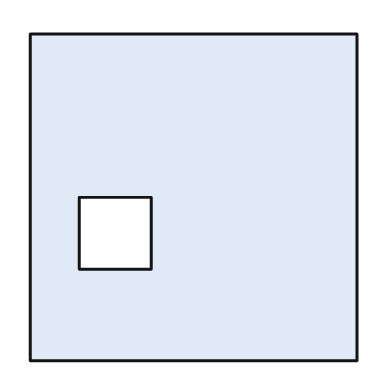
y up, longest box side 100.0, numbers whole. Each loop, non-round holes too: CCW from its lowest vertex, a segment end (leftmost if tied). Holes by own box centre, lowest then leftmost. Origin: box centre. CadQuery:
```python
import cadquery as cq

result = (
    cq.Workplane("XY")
    .moveTo(-50.0, -50.0)
    .lineTo(50.0, -50.0)
    .lineTo(50.0, 50.0)
    .lineTo(-50.0, 50.0)
    .close()
    .moveTo(-35.0, -22.0)
    .lineTo(-13.0, -22.0)
    .lineTo(-13.0, 0.0)
    .lineTo(-35.0, 0.0)
    .close()
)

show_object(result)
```